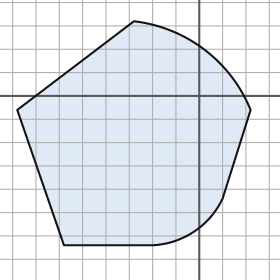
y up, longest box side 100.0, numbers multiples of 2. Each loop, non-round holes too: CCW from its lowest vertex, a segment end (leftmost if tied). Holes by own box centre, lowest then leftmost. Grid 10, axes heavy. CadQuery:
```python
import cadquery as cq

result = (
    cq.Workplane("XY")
    .moveTo(-58.0, -64.0)
    .lineTo(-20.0, -64.0)
    .threePointArc((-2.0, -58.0), (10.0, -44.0))
    .lineTo(22.0, -6.0)
    .threePointArc((2.0, 20.0), (-28.0, 32.0))
    .lineTo(-78.0, -6.0)
    .close()
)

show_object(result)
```